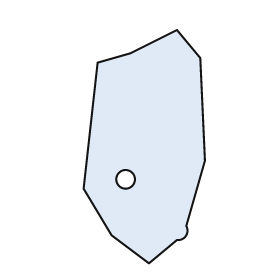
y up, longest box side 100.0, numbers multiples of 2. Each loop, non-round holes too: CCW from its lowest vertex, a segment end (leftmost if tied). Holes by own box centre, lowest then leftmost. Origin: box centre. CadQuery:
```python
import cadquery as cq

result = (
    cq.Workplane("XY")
    .moveTo(2.0, -50.0)
    .lineTo(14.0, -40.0)
    .threePointArc((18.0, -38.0), (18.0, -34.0))
    .lineTo(26.0, -6.0)
    .lineTo(24.0, 38.0)
    .lineTo(14.0, 50.0)
    .lineTo(-6.0, 40.0)
    .lineTo(-20.0, 36.0)
    .lineTo(-26.0, -18.0)
    .lineTo(-14.0, -38.0)
    .close()
    .moveTo(-8.0, -14.0)
    .circle(4.0)
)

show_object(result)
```